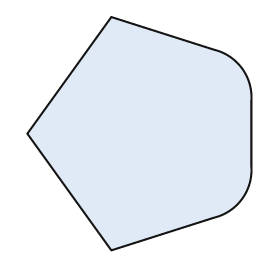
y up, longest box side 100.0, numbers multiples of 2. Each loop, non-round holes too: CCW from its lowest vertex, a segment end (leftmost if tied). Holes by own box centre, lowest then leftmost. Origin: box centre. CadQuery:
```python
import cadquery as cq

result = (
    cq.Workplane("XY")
    .moveTo(-12.0, -50.0)
    .lineTo(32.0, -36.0)
    .threePointArc((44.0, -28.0), (48.0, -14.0))
    .lineTo(48.0, 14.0)
    .threePointArc((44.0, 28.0), (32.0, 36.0))
    .lineTo(-12.0, 50.0)
    .lineTo(-48.0, 0.0)
    .close()
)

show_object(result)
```